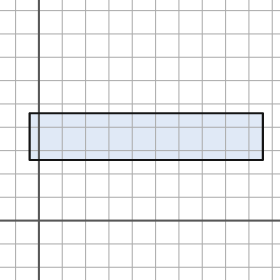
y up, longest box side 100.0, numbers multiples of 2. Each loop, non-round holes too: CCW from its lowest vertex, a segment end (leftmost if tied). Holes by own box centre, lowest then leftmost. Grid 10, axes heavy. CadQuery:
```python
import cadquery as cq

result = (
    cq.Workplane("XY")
    .moveTo(-4.0, 26.0)
    .lineTo(96.0, 26.0)
    .lineTo(96.0, 46.0)
    .lineTo(-4.0, 46.0)
    .close()
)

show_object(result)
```